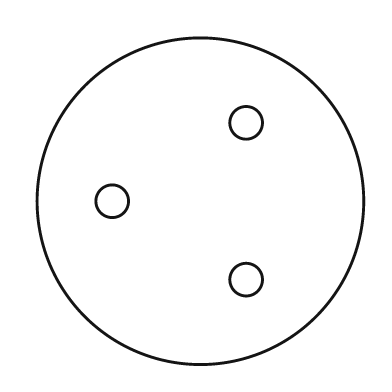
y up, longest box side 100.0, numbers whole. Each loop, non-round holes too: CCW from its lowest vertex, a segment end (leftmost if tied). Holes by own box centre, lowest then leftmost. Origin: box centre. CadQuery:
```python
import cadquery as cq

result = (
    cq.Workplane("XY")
    .moveTo(0.0, 0.0)
    .circle(50.0)
    .moveTo(14.0, -24.0)
    .circle(5.0)
    .moveTo(-27.0, 0.0)
    .circle(5.0)
    .moveTo(14.0, 24.0)
    .circle(5.0)
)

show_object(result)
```